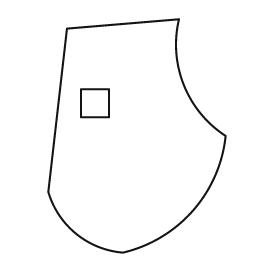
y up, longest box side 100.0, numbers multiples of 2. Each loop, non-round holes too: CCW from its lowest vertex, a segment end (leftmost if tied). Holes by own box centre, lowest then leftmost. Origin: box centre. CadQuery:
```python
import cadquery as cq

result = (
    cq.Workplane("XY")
    .moveTo(-6.0, -50.0)
    .threePointArc((24.0, -32.0), (38.0, 0.0))
    .threePointArc((20.0, 22.0), (18.0, 50.0))
    .lineTo(-30.0, 46.0)
    .lineTo(-38.0, -24.0)
    .threePointArc((-26.0, -42.0), (-6.0, -50.0))
    .close()
    .moveTo(-24.0, 8.0)
    .lineTo(-12.0, 8.0)
    .lineTo(-12.0, 20.0)
    .lineTo(-24.0, 20.0)
    .close()
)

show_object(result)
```